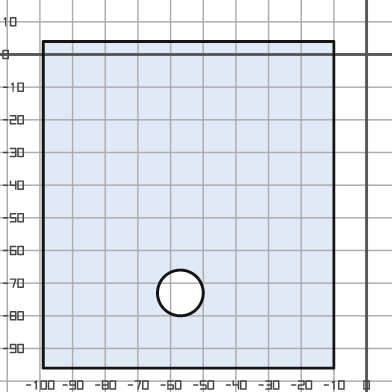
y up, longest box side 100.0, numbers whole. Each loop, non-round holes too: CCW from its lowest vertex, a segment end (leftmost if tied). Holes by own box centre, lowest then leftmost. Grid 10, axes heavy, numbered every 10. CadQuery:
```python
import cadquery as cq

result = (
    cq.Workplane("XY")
    .moveTo(-99.0, -96.0)
    .lineTo(-10.0, -96.0)
    .lineTo(-10.0, 4.0)
    .lineTo(-99.0, 4.0)
    .close()
    .moveTo(-57.0, -73.0)
    .circle(7.0)
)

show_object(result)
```